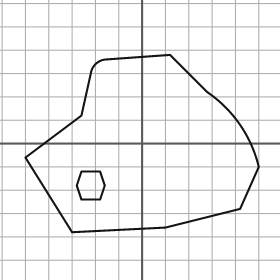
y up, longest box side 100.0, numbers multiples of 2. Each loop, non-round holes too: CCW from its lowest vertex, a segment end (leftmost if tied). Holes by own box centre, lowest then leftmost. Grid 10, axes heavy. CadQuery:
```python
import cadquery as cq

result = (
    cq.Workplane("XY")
    .moveTo(-30.0, -38.0)
    .lineTo(10.0, -36.0)
    .lineTo(42.0, -28.0)
    .lineTo(50.0, -10.0)
    .threePointArc((42.0, 8.0), (28.0, 22.0))
    .lineTo(12.0, 38.0)
    .lineTo(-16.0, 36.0)
    .threePointArc((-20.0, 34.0), (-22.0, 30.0))
    .lineTo(-26.0, 12.0)
    .lineTo(-50.0, -6.0)
    .close()
    .moveTo(-26.0, -24.0)
    .lineTo(-18.0, -24.0)
    .lineTo(-16.0, -18.0)
    .lineTo(-18.0, -12.0)
    .lineTo(-26.0, -12.0)
    .lineTo(-28.0, -18.0)
    .close()
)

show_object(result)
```